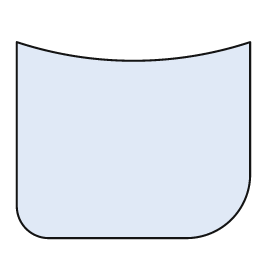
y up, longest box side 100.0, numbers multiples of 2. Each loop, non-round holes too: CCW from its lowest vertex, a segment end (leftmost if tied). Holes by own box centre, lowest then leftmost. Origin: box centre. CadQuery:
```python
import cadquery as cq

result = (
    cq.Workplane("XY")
    .moveTo(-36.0, -42.0)
    .lineTo(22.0, -42.0)
    .threePointArc((42.0, -34.0), (50.0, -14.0))
    .lineTo(50.0, 42.0)
    .threePointArc((0.0, 34.0), (-50.0, 42.0))
    .lineTo(-50.0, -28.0)
    .threePointArc((-46.0, -38.0), (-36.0, -42.0))
    .close()
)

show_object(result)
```